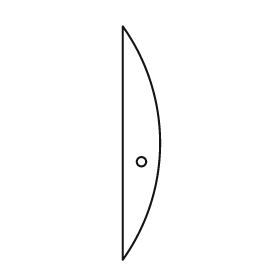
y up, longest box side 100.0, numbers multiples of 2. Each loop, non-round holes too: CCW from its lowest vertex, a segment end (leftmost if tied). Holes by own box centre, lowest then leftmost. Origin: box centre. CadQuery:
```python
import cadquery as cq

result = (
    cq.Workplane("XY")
    .moveTo(-8.0, -50.0)
    .threePointArc((8.0, 0.0), (-8.0, 50.0))
    .close()
    .moveTo(0.0, -8.0)
    .circle(2.0)
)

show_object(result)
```